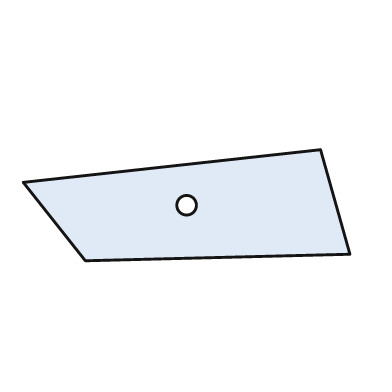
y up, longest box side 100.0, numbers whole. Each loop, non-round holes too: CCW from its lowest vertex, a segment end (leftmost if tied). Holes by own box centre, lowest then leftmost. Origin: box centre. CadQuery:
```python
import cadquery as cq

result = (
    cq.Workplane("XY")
    .moveTo(-31.0, -17.0)
    .lineTo(50.0, -15.0)
    .lineTo(41.0, 17.0)
    .lineTo(-50.0, 7.0)
    .close()
    .moveTo(0.0, 0.0)
    .circle(3.0)
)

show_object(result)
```